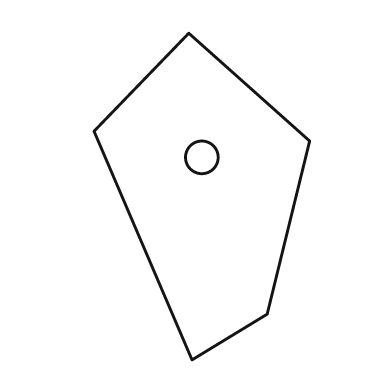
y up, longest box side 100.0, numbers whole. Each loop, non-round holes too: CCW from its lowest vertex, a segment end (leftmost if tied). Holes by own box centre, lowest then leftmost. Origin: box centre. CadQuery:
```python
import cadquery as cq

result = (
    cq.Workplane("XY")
    .moveTo(-3.0, -50.0)
    .lineTo(20.0, -36.0)
    .lineTo(33.0, 17.0)
    .lineTo(-4.0, 50.0)
    .lineTo(-33.0, 20.0)
    .close()
    .moveTo(0.0, 12.0)
    .circle(5.0)
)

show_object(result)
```